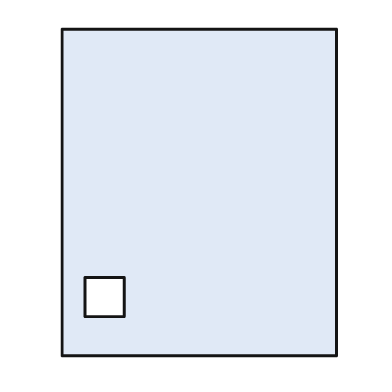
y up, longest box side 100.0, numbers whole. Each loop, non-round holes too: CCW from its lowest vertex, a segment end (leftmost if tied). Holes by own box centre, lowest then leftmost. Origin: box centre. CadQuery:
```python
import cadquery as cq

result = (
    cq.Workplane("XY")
    .moveTo(-42.0, -50.0)
    .lineTo(42.0, -50.0)
    .lineTo(42.0, 50.0)
    .lineTo(-42.0, 50.0)
    .close()
    .moveTo(-35.0, -38.0)
    .lineTo(-23.0, -38.0)
    .lineTo(-23.0, -26.0)
    .lineTo(-35.0, -26.0)
    .close()
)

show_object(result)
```